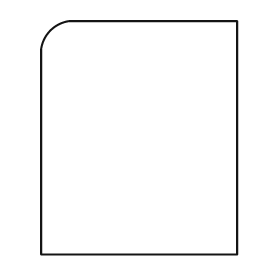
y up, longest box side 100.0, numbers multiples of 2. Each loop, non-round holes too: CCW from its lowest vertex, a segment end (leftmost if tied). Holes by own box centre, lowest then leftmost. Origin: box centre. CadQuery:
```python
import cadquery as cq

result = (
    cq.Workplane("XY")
    .moveTo(-42.0, -50.0)
    .lineTo(42.0, -50.0)
    .lineTo(42.0, 50.0)
    .lineTo(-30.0, 50.0)
    .threePointArc((-38.0, 46.0), (-42.0, 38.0))
    .close()
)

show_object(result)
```